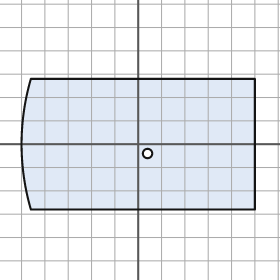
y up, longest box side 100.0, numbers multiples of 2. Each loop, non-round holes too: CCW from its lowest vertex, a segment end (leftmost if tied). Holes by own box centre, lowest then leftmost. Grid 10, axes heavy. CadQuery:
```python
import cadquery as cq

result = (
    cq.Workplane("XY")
    .moveTo(-46.0, -28.0)
    .lineTo(50.0, -28.0)
    .lineTo(50.0, 28.0)
    .lineTo(-46.0, 28.0)
    .threePointArc((-50.0, 0.0), (-46.0, -28.0))
    .close()
    .moveTo(4.0, -4.0)
    .circle(2.0)
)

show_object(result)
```